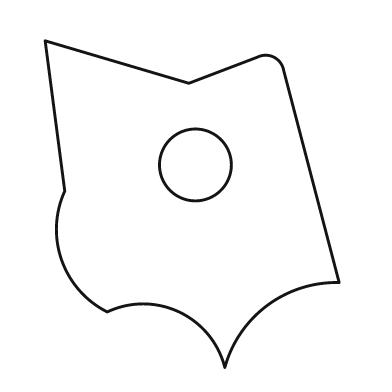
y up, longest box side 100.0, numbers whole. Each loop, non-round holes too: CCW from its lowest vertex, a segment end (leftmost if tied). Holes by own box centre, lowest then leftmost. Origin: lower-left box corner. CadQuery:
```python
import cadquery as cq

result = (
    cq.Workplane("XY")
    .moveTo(55.0, 0.0)
    .threePointArc((68.0, 19.0), (90.0, 26.0))
    .lineTo(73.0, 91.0)
    .threePointArc((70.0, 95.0), (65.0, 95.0))
    .lineTo(44.0, 87.0)
    .lineTo(0.0, 100.0)
    .lineTo(6.0, 54.0)
    .threePointArc((5.0, 33.0), (19.0, 17.0))
    .threePointArc((41.0, 17.0), (55.0, 0.0))
    .close()
    .moveTo(46.0, 62.0)
    .circle(11.0)
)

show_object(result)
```